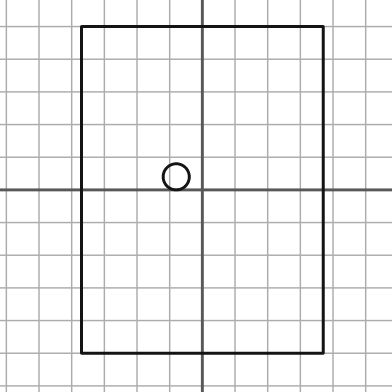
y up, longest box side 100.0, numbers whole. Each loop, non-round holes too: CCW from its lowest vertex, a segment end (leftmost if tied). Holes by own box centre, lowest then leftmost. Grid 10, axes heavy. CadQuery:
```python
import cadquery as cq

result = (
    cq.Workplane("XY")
    .moveTo(-37.0, -50.0)
    .lineTo(37.0, -50.0)
    .lineTo(37.0, 50.0)
    .lineTo(-37.0, 50.0)
    .close()
    .moveTo(-8.0, 4.0)
    .circle(4.0)
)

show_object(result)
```